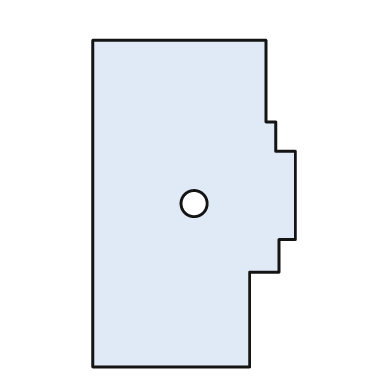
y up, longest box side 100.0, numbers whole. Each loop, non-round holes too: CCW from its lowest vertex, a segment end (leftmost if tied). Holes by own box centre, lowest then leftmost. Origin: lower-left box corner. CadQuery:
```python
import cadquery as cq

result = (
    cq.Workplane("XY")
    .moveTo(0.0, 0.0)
    .lineTo(48.0, 0.0)
    .lineTo(48.0, 29.0)
    .lineTo(57.0, 29.0)
    .lineTo(57.0, 39.0)
    .lineTo(62.0, 39.0)
    .lineTo(62.0, 66.0)
    .lineTo(56.0, 66.0)
    .lineTo(56.0, 75.0)
    .lineTo(53.0, 75.0)
    .lineTo(53.0, 100.0)
    .lineTo(0.0, 100.0)
    .close()
    .moveTo(31.0, 50.0)
    .circle(4.0)
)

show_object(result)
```